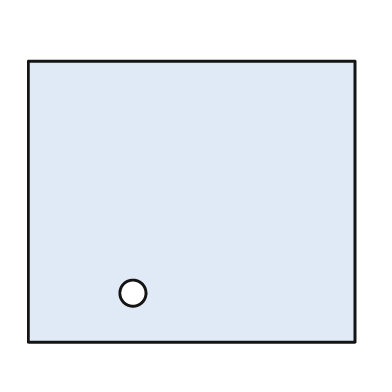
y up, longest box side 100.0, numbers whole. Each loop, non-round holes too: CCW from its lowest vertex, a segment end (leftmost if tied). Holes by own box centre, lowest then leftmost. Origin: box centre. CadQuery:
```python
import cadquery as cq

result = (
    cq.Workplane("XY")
    .moveTo(-50.0, -43.0)
    .lineTo(50.0, -43.0)
    .lineTo(50.0, 43.0)
    .lineTo(-50.0, 43.0)
    .close()
    .moveTo(-18.0, -28.0)
    .circle(4.0)
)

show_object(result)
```